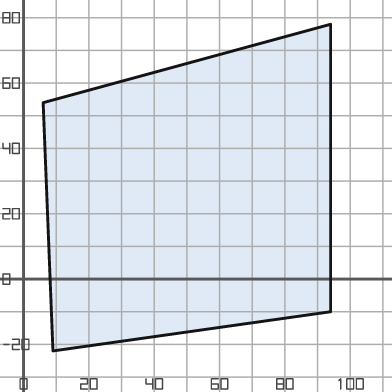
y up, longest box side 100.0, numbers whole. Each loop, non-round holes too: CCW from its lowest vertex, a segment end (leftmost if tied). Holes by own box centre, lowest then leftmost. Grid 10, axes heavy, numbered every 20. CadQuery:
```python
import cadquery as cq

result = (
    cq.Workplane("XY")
    .moveTo(9.0, -22.0)
    .lineTo(94.0, -10.0)
    .lineTo(94.0, 78.0)
    .lineTo(6.0, 54.0)
    .close()
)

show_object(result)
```